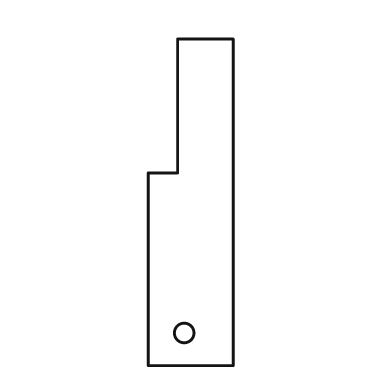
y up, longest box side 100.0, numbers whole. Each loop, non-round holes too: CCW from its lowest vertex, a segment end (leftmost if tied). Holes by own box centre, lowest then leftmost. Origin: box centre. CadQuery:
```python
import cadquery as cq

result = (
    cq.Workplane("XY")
    .moveTo(-13.0, -50.0)
    .lineTo(13.0, -50.0)
    .lineTo(13.0, 50.0)
    .lineTo(-4.0, 50.0)
    .lineTo(-4.0, 9.0)
    .lineTo(-13.0, 9.0)
    .close()
    .moveTo(-2.0, -40.0)
    .circle(3.0)
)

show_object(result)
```